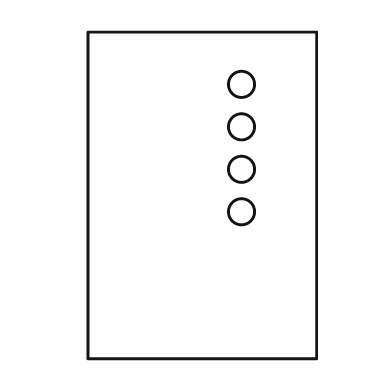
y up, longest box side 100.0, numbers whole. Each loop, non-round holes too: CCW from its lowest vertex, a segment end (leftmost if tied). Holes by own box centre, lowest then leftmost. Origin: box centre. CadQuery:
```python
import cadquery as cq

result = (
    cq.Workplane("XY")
    .moveTo(-35.0, -50.0)
    .lineTo(35.0, -50.0)
    .lineTo(35.0, 50.0)
    .lineTo(-35.0, 50.0)
    .close()
    .moveTo(12.0, -5.0)
    .circle(4.0)
    .moveTo(12.0, 8.0)
    .circle(4.0)
    .moveTo(12.0, 21.0)
    .circle(4.0)
    .moveTo(12.0, 34.0)
    .circle(4.0)
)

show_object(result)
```